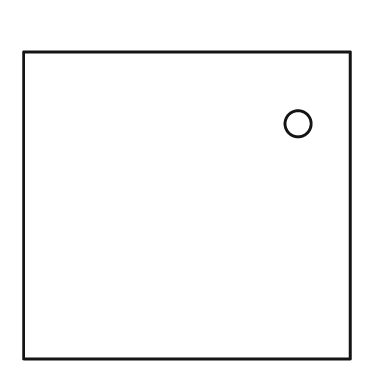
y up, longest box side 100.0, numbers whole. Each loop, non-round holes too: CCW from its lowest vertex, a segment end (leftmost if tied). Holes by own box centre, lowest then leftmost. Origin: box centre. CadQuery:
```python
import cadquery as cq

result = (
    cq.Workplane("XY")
    .moveTo(-50.0, -47.0)
    .lineTo(50.0, -47.0)
    .lineTo(50.0, 47.0)
    .lineTo(-50.0, 47.0)
    .close()
    .moveTo(34.0, 25.0)
    .circle(4.0)
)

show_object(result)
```